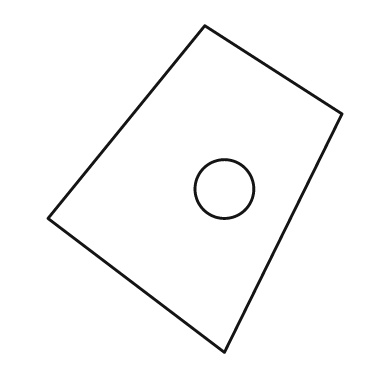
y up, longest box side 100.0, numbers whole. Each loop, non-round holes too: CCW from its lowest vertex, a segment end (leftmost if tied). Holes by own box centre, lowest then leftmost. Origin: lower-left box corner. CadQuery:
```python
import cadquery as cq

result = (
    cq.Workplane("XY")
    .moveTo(54.0, 0.0)
    .lineTo(90.0, 73.0)
    .lineTo(48.0, 100.0)
    .lineTo(0.0, 41.0)
    .close()
    .moveTo(54.0, 50.0)
    .circle(9.0)
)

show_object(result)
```